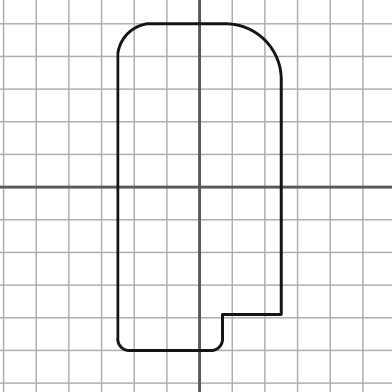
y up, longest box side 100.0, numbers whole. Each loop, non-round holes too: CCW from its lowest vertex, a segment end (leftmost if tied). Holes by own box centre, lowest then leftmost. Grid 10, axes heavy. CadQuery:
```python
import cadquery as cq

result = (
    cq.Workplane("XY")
    .moveTo(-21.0, -50.0)
    .lineTo(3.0, -50.0)
    .threePointArc((6.0, -49.0), (7.0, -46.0))
    .lineTo(7.0, -39.0)
    .lineTo(25.0, -39.0)
    .lineTo(25.0, 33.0)
    .threePointArc((20.0, 45.0), (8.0, 50.0))
    .lineTo(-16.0, 50.0)
    .threePointArc((-22.0, 47.0), (-25.0, 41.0))
    .lineTo(-25.0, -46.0)
    .threePointArc((-24.0, -49.0), (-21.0, -50.0))
    .close()
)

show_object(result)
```